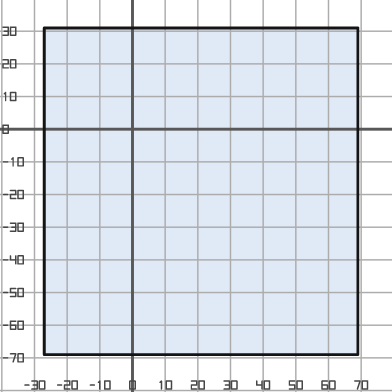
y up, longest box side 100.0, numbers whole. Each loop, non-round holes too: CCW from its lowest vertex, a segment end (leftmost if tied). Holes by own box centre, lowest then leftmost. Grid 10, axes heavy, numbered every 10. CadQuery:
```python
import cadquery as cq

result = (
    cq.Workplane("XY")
    .moveTo(-27.0, -69.0)
    .lineTo(69.0, -69.0)
    .lineTo(69.0, 31.0)
    .lineTo(-27.0, 31.0)
    .close()
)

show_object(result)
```